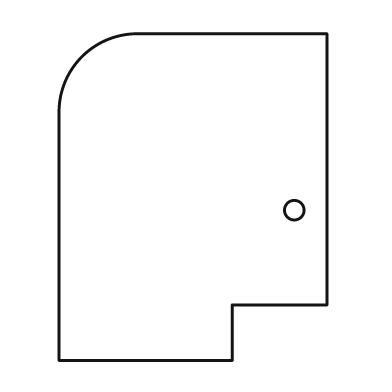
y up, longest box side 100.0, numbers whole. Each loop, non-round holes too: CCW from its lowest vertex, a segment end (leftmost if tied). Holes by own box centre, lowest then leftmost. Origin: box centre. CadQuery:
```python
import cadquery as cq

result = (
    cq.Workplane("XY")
    .moveTo(-41.0, -50.0)
    .lineTo(12.0, -50.0)
    .lineTo(12.0, -33.0)
    .lineTo(41.0, -33.0)
    .lineTo(41.0, 50.0)
    .lineTo(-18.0, 50.0)
    .threePointArc((-34.0, 43.0), (-41.0, 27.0))
    .close()
    .moveTo(31.0, -4.0)
    .circle(3.0)
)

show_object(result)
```